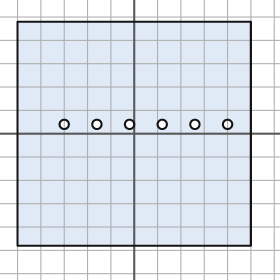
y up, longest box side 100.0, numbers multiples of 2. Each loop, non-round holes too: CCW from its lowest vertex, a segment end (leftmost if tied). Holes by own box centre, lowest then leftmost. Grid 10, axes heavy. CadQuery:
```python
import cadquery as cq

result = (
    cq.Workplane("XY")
    .moveTo(-50.0, -48.0)
    .lineTo(50.0, -48.0)
    .lineTo(50.0, 48.0)
    .lineTo(-50.0, 48.0)
    .close()
    .moveTo(-30.0, 4.0)
    .circle(2.0)
    .moveTo(-16.0, 4.0)
    .circle(2.0)
    .moveTo(-2.0, 4.0)
    .circle(2.0)
    .moveTo(12.0, 4.0)
    .circle(2.0)
    .moveTo(26.0, 4.0)
    .circle(2.0)
    .moveTo(40.0, 4.0)
    .circle(2.0)
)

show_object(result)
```